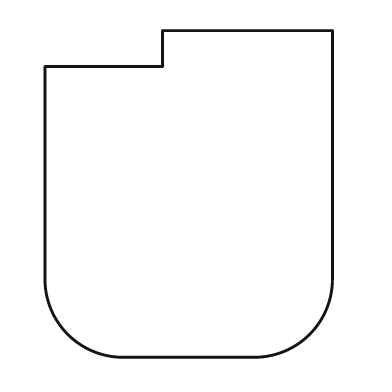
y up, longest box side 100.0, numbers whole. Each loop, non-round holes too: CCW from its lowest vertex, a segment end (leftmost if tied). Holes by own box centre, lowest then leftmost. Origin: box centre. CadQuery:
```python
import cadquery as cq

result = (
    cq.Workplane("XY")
    .moveTo(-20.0, -50.0)
    .lineTo(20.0, -50.0)
    .threePointArc((37.0, -43.0), (44.0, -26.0))
    .lineTo(44.0, 50.0)
    .lineTo(-8.0, 50.0)
    .lineTo(-8.0, 39.0)
    .lineTo(-44.0, 39.0)
    .lineTo(-44.0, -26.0)
    .threePointArc((-37.0, -43.0), (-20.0, -50.0))
    .close()
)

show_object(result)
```